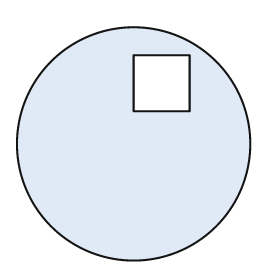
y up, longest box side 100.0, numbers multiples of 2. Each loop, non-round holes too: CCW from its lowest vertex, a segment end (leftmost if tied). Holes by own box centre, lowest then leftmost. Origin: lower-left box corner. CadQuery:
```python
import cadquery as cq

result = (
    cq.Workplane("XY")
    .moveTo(50.0, 50.0)
    .circle(50.0)
    .moveTo(50.0, 64.0)
    .lineTo(74.0, 64.0)
    .lineTo(74.0, 88.0)
    .lineTo(50.0, 88.0)
    .close()
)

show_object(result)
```